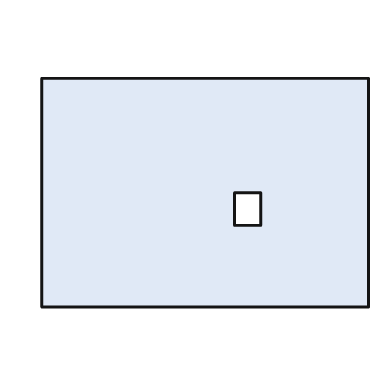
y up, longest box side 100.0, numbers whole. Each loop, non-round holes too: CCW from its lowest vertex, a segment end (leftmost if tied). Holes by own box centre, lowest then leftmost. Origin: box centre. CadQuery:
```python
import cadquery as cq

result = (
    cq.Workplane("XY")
    .moveTo(-50.0, -35.0)
    .lineTo(50.0, -35.0)
    .lineTo(50.0, 35.0)
    .lineTo(-50.0, 35.0)
    .close()
    .moveTo(9.0, -10.0)
    .lineTo(17.0, -10.0)
    .lineTo(17.0, 0.0)
    .lineTo(9.0, 0.0)
    .close()
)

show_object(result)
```